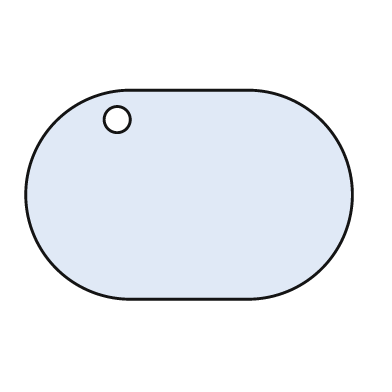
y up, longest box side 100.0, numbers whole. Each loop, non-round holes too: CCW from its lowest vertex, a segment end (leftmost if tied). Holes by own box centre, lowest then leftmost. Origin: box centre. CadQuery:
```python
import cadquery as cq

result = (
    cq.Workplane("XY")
    .moveTo(-18.0, -32.0)
    .lineTo(18.0, -32.0)
    .threePointArc((50.0, 0.0), (18.0, 32.0))
    .lineTo(-18.0, 32.0)
    .threePointArc((-50.0, 0.0), (-18.0, -32.0))
    .close()
    .moveTo(-22.0, 23.0)
    .circle(4.0)
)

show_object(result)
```